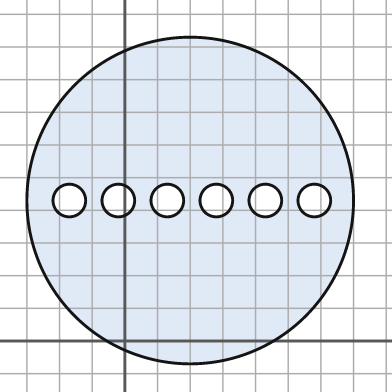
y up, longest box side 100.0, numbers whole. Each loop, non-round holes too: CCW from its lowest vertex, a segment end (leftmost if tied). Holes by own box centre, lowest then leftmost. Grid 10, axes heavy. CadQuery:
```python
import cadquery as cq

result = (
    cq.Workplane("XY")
    .moveTo(20.0, 43.0)
    .circle(50.0)
    .moveTo(-17.0, 43.0)
    .circle(5.0)
    .moveTo(-2.0, 43.0)
    .circle(5.0)
    .moveTo(13.0, 43.0)
    .circle(5.0)
    .moveTo(28.0, 43.0)
    .circle(5.0)
    .moveTo(43.0, 43.0)
    .circle(5.0)
    .moveTo(58.0, 43.0)
    .circle(5.0)
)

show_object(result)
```